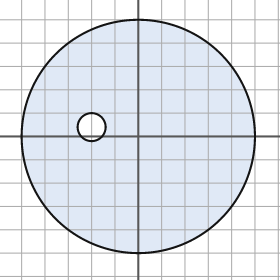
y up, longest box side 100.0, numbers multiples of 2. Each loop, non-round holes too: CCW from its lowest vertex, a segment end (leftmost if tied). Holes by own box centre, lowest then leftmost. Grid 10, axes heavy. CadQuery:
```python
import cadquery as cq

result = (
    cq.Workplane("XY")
    .moveTo(0.0, 0.0)
    .circle(50.0)
    .moveTo(-20.0, 4.0)
    .circle(6.0)
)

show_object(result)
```